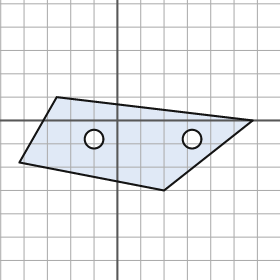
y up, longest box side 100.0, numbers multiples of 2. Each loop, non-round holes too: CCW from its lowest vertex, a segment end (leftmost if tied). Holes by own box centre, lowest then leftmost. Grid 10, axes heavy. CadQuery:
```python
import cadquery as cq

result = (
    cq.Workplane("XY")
    .moveTo(20.0, -30.0)
    .lineTo(58.0, 0.0)
    .lineTo(-26.0, 10.0)
    .lineTo(-42.0, -18.0)
    .close()
    .moveTo(-10.0, -8.0)
    .circle(4.0)
    .moveTo(32.0, -8.0)
    .circle(4.0)
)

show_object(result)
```